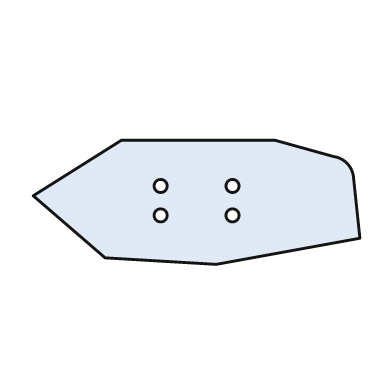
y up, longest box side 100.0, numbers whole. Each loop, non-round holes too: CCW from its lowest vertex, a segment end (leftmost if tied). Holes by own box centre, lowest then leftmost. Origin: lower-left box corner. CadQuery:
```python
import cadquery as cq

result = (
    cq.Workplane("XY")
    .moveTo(56.0, 0.0)
    .lineTo(100.0, 8.0)
    .lineTo(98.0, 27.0)
    .threePointArc((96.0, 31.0), (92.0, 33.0))
    .lineTo(74.0, 38.0)
    .lineTo(27.0, 38.0)
    .lineTo(0.0, 21.0)
    .lineTo(22.0, 2.0)
    .close()
    .moveTo(39.0, 15.0)
    .circle(2.0)
    .moveTo(61.0, 15.0)
    .circle(2.0)
    .moveTo(39.0, 24.0)
    .circle(2.0)
    .moveTo(61.0, 24.0)
    .circle(2.0)
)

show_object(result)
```